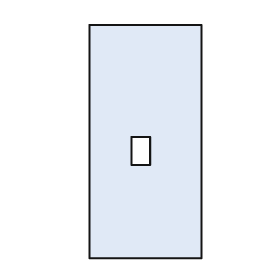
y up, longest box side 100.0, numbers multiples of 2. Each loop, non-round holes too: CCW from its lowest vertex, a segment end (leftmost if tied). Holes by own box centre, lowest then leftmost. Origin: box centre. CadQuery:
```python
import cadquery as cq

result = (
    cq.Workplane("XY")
    .moveTo(-24.0, -50.0)
    .lineTo(24.0, -50.0)
    .lineTo(24.0, 50.0)
    .lineTo(-24.0, 50.0)
    .close()
    .moveTo(-6.0, -10.0)
    .lineTo(2.0, -10.0)
    .lineTo(2.0, 2.0)
    .lineTo(-6.0, 2.0)
    .close()
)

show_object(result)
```